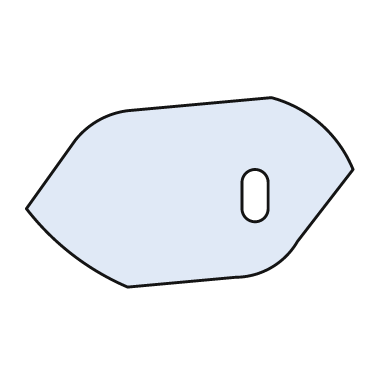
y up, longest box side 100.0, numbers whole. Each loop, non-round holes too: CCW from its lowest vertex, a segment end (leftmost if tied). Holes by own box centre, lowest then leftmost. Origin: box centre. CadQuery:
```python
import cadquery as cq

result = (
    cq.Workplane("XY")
    .moveTo(-19.0, -29.0)
    .lineTo(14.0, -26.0)
    .threePointArc((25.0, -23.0), (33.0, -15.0))
    .lineTo(50.0, 7.0)
    .threePointArc((40.0, 21.0), (25.0, 29.0))
    .lineTo(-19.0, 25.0)
    .threePointArc((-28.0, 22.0), (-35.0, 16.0))
    .lineTo(-50.0, -5.0)
    .threePointArc((-36.0, -19.0), (-19.0, -29.0))
    .close()
    .moveTo(16.0, -5.0)
    .threePointArc((20.0, -9.0), (24.0, -5.0))
    .lineTo(24.0, 3.0)
    .threePointArc((20.0, 7.0), (16.0, 3.0))
    .close()
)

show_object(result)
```